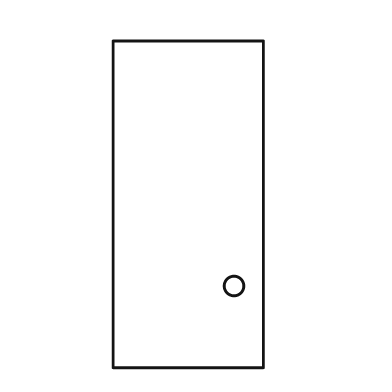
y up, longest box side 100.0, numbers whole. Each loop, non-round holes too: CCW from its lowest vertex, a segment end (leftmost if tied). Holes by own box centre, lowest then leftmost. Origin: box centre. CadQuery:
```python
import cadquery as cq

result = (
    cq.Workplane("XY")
    .moveTo(-23.0, -50.0)
    .lineTo(23.0, -50.0)
    .lineTo(23.0, 50.0)
    .lineTo(-23.0, 50.0)
    .close()
    .moveTo(14.0, -25.0)
    .circle(3.0)
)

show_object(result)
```